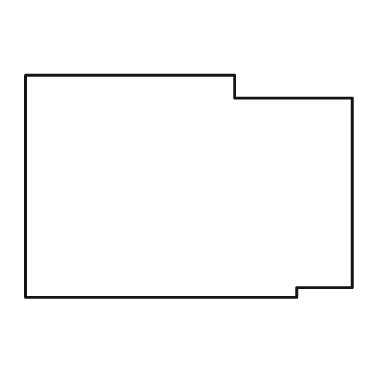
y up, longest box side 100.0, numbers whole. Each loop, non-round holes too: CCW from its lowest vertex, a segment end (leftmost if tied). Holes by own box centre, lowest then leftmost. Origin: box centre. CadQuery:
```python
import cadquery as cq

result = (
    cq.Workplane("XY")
    .moveTo(-50.0, -34.0)
    .lineTo(33.0, -34.0)
    .lineTo(33.0, -31.0)
    .lineTo(50.0, -31.0)
    .lineTo(50.0, 27.0)
    .lineTo(14.0, 27.0)
    .lineTo(14.0, 34.0)
    .lineTo(-50.0, 34.0)
    .close()
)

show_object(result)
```